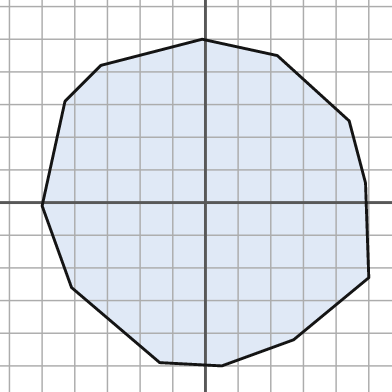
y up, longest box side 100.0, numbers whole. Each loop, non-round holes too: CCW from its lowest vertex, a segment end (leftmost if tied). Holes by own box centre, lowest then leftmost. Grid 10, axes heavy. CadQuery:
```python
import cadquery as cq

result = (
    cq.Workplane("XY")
    .moveTo(5.0, -50.0)
    .lineTo(27.0, -42.0)
    .lineTo(50.0, -23.0)
    .lineTo(49.0, 6.0)
    .lineTo(44.0, 25.0)
    .lineTo(22.0, 45.0)
    .lineTo(-1.0, 50.0)
    .lineTo(-32.0, 42.0)
    .lineTo(-43.0, 31.0)
    .lineTo(-50.0, -1.0)
    .lineTo(-41.0, -26.0)
    .lineTo(-14.0, -49.0)
    .close()
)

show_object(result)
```